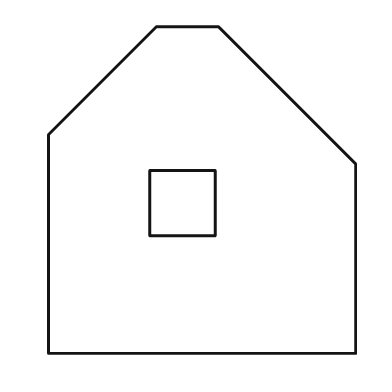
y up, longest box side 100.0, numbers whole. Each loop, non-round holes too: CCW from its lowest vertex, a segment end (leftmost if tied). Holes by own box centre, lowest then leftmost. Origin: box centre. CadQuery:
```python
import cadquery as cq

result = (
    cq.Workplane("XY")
    .moveTo(-47.0, -50.0)
    .lineTo(47.0, -50.0)
    .lineTo(47.0, 8.0)
    .lineTo(5.0, 50.0)
    .lineTo(-14.0, 50.0)
    .lineTo(-47.0, 17.0)
    .close()
    .moveTo(-16.0, -14.0)
    .lineTo(4.0, -14.0)
    .lineTo(4.0, 6.0)
    .lineTo(-16.0, 6.0)
    .close()
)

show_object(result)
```